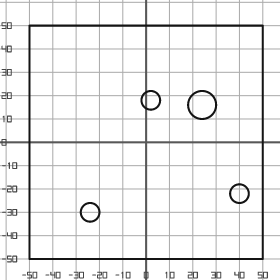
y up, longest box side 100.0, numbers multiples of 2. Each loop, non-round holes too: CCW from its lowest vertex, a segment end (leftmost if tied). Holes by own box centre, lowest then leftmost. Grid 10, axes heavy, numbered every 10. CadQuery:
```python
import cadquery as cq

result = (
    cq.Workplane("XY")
    .moveTo(-50.0, -50.0)
    .lineTo(50.0, -50.0)
    .lineTo(50.0, 50.0)
    .lineTo(-50.0, 50.0)
    .close()
    .moveTo(-24.0, -30.0)
    .circle(4.0)
    .moveTo(40.0, -22.0)
    .circle(4.0)
    .moveTo(24.0, 16.0)
    .circle(6.0)
    .moveTo(2.0, 18.0)
    .circle(4.0)
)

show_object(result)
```